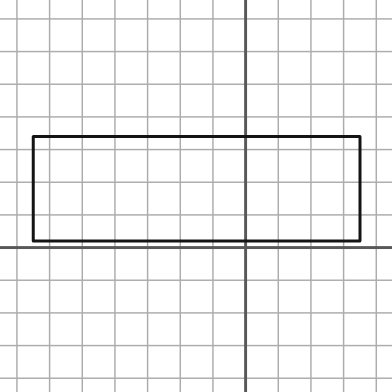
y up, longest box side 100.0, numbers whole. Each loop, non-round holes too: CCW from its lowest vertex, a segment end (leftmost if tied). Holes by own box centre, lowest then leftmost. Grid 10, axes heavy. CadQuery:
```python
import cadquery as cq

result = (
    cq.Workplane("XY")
    .moveTo(-65.0, 2.0)
    .lineTo(35.0, 2.0)
    .lineTo(35.0, 34.0)
    .lineTo(-65.0, 34.0)
    .close()
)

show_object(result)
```